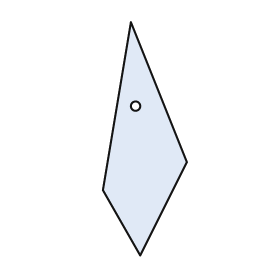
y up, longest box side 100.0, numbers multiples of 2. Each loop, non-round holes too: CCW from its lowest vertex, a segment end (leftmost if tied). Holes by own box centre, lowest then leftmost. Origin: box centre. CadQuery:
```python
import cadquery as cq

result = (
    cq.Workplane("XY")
    .moveTo(-2.0, -50.0)
    .lineTo(18.0, -10.0)
    .lineTo(-6.0, 50.0)
    .lineTo(-18.0, -22.0)
    .close()
    .moveTo(-4.0, 14.0)
    .circle(2.0)
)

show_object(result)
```